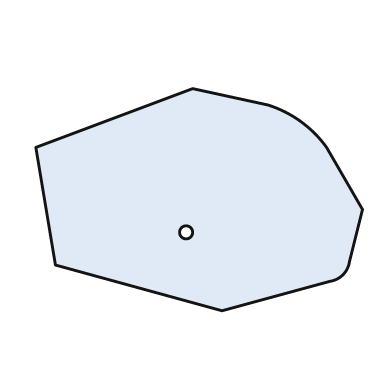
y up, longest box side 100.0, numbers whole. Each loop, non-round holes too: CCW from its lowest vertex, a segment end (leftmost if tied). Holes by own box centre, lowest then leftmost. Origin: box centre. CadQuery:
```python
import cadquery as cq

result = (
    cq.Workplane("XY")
    .moveTo(7.0, -34.0)
    .lineTo(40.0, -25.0)
    .threePointArc((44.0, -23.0), (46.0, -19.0))
    .lineTo(50.0, -3.0)
    .lineTo(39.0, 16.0)
    .threePointArc((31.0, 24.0), (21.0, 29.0))
    .lineTo(-2.0, 34.0)
    .lineTo(-50.0, 16.0)
    .lineTo(-44.0, -20.0)
    .close()
    .moveTo(-4.0, -10.0)
    .circle(2.0)
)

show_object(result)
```